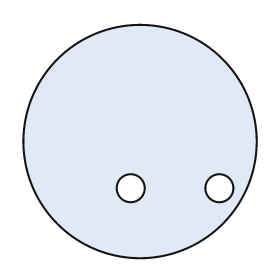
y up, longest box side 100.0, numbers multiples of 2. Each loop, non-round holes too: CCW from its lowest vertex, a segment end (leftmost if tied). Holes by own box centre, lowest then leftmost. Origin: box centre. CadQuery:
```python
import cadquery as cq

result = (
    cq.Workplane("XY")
    .moveTo(0.0, 0.0)
    .circle(50.0)
    .moveTo(-4.0, -20.0)
    .circle(6.0)
    .moveTo(34.0, -20.0)
    .circle(6.0)
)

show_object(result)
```